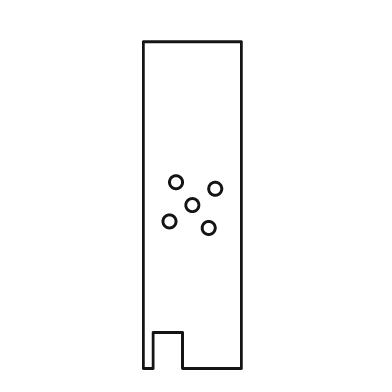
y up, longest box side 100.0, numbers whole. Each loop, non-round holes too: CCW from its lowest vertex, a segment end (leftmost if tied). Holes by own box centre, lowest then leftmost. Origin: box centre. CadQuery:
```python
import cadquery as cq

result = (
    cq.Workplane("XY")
    .moveTo(-15.0, -50.0)
    .lineTo(-12.0, -50.0)
    .lineTo(-12.0, -39.0)
    .lineTo(-3.0, -39.0)
    .lineTo(-3.0, -50.0)
    .lineTo(15.0, -50.0)
    .lineTo(15.0, 50.0)
    .lineTo(-15.0, 50.0)
    .close()
    .moveTo(5.0, -7.0)
    .circle(2.0)
    .moveTo(-7.0, -5.0)
    .circle(2.0)
    .moveTo(0.0, 0.0)
    .circle(2.0)
    .moveTo(7.0, 5.0)
    .circle(2.0)
    .moveTo(-5.0, 7.0)
    .circle(2.0)
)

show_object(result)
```